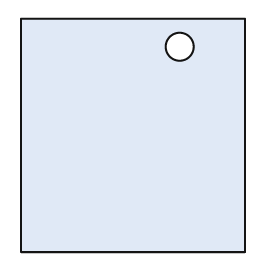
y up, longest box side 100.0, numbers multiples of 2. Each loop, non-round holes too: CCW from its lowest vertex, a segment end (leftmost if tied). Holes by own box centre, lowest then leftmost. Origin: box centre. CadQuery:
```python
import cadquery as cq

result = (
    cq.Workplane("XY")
    .moveTo(-48.0, -50.0)
    .lineTo(48.0, -50.0)
    .lineTo(48.0, 50.0)
    .lineTo(-48.0, 50.0)
    .close()
    .moveTo(20.0, 38.0)
    .circle(6.0)
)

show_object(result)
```